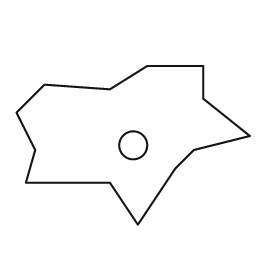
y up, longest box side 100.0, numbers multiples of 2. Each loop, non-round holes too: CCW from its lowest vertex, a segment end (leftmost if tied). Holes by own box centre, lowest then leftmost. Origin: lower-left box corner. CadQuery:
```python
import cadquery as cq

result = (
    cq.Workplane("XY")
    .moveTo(52.0, 0.0)
    .lineTo(68.0, 24.0)
    .lineTo(76.0, 32.0)
    .lineTo(100.0, 38.0)
    .lineTo(80.0, 54.0)
    .lineTo(80.0, 68.0)
    .lineTo(56.0, 68.0)
    .lineTo(40.0, 58.0)
    .lineTo(12.0, 60.0)
    .lineTo(0.0, 48.0)
    .lineTo(8.0, 32.0)
    .lineTo(4.0, 18.0)
    .lineTo(40.0, 18.0)
    .close()
    .moveTo(50.0, 34.0)
    .circle(6.0)
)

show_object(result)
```